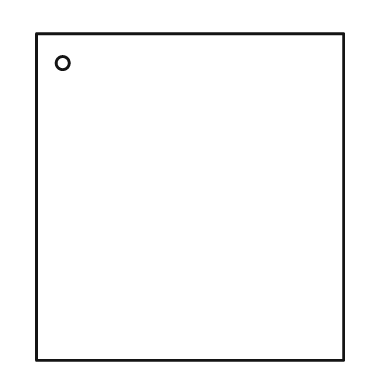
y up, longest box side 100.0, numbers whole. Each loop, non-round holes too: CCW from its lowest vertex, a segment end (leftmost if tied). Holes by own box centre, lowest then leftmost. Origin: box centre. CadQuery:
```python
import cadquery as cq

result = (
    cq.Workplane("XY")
    .moveTo(-47.0, -50.0)
    .lineTo(47.0, -50.0)
    .lineTo(47.0, 50.0)
    .lineTo(-47.0, 50.0)
    .close()
    .moveTo(-39.0, 41.0)
    .circle(2.0)
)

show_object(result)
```